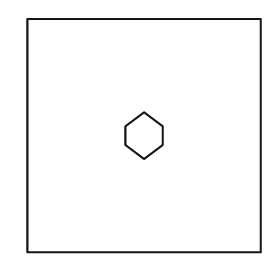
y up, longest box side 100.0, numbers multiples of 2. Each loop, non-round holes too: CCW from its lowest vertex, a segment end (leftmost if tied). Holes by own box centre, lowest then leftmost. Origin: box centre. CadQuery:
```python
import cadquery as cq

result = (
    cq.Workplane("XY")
    .moveTo(-50.0, -50.0)
    .lineTo(50.0, -50.0)
    .lineTo(50.0, 50.0)
    .lineTo(-50.0, 50.0)
    .close()
    .moveTo(0.0, -10.0)
    .lineTo(8.0, -4.0)
    .lineTo(8.0, 4.0)
    .lineTo(0.0, 10.0)
    .lineTo(-8.0, 4.0)
    .lineTo(-8.0, -4.0)
    .close()
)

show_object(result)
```